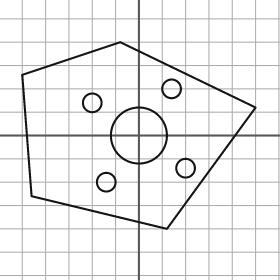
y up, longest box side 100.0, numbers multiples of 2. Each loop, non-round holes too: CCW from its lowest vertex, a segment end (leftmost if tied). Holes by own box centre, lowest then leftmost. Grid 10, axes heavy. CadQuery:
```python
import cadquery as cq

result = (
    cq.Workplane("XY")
    .moveTo(12.0, -40.0)
    .lineTo(50.0, 12.0)
    .lineTo(-8.0, 40.0)
    .lineTo(-50.0, 26.0)
    .lineTo(-46.0, -26.0)
    .close()
    .moveTo(-14.0, -20.0)
    .circle(4.0)
    .moveTo(20.0, -14.0)
    .circle(4.0)
    .moveTo(0.0, 0.0)
    .circle(12.0)
    .moveTo(-20.0, 14.0)
    .circle(4.0)
    .moveTo(14.0, 20.0)
    .circle(4.0)
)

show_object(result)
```